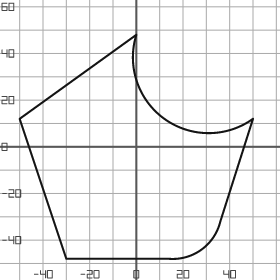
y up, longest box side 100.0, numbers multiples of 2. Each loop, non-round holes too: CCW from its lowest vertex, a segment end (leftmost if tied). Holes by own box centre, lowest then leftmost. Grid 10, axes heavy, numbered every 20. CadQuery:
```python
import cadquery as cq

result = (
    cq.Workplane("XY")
    .moveTo(-30.0, -48.0)
    .lineTo(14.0, -48.0)
    .threePointArc((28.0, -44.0), (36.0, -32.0))
    .lineTo(50.0, 12.0)
    .threePointArc((12.0, 12.0), (0.0, 48.0))
    .lineTo(-50.0, 12.0)
    .close()
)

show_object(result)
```